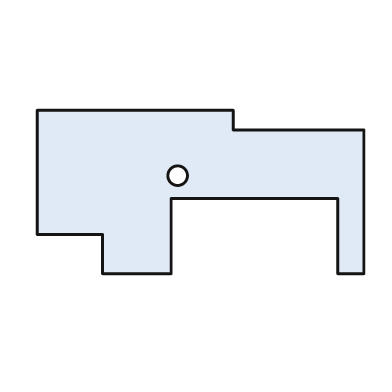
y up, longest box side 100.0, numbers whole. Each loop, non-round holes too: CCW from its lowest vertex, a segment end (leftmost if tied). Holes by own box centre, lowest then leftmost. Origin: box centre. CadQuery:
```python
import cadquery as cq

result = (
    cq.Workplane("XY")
    .moveTo(-30.0, -25.0)
    .lineTo(-9.0, -25.0)
    .lineTo(-9.0, -2.0)
    .lineTo(42.0, -2.0)
    .lineTo(42.0, -25.0)
    .lineTo(50.0, -25.0)
    .lineTo(50.0, 19.0)
    .lineTo(10.0, 19.0)
    .lineTo(10.0, 25.0)
    .lineTo(-50.0, 25.0)
    .lineTo(-50.0, -13.0)
    .lineTo(-30.0, -13.0)
    .close()
    .moveTo(-7.0, 5.0)
    .circle(3.0)
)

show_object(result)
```